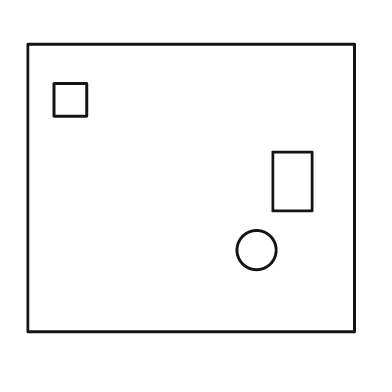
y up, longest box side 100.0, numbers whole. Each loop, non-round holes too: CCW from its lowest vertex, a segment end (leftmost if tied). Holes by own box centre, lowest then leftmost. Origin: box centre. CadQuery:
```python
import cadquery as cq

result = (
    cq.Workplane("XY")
    .moveTo(-50.0, -44.0)
    .lineTo(50.0, -44.0)
    .lineTo(50.0, 44.0)
    .lineTo(-50.0, 44.0)
    .close()
    .moveTo(20.0, -19.0)
    .circle(6.0)
    .moveTo(25.0, -7.0)
    .lineTo(37.0, -7.0)
    .lineTo(37.0, 11.0)
    .lineTo(25.0, 11.0)
    .close()
    .moveTo(-42.0, 22.0)
    .lineTo(-32.0, 22.0)
    .lineTo(-32.0, 32.0)
    .lineTo(-42.0, 32.0)
    .close()
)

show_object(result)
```